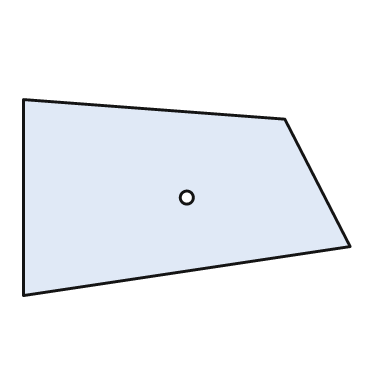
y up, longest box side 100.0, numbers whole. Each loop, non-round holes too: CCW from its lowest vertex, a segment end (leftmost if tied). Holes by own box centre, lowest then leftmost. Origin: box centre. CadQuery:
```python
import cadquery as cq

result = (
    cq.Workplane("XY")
    .moveTo(-50.0, -30.0)
    .lineTo(50.0, -15.0)
    .lineTo(30.0, 24.0)
    .lineTo(-50.0, 30.0)
    .close()
    .moveTo(0.0, 0.0)
    .circle(2.0)
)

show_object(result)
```